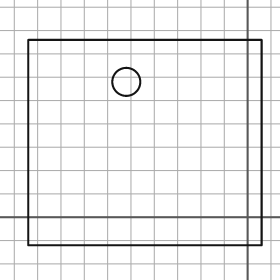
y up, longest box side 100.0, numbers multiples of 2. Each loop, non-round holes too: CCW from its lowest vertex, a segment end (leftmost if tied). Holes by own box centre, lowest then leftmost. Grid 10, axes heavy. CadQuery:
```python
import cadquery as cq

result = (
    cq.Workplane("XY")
    .moveTo(-94.0, -12.0)
    .lineTo(6.0, -12.0)
    .lineTo(6.0, 76.0)
    .lineTo(-94.0, 76.0)
    .close()
    .moveTo(-52.0, 58.0)
    .circle(6.0)
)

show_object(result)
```